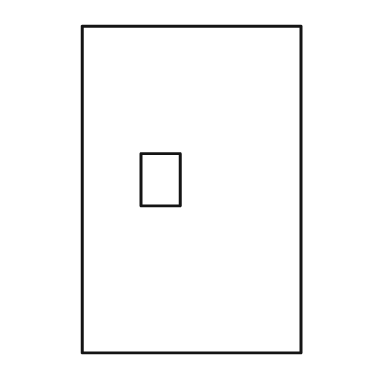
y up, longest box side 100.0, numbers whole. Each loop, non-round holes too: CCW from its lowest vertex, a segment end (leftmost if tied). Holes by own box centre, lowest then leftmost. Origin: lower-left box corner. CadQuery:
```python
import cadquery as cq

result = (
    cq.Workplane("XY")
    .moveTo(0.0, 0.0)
    .lineTo(67.0, 0.0)
    .lineTo(67.0, 100.0)
    .lineTo(0.0, 100.0)
    .close()
    .moveTo(18.0, 45.0)
    .lineTo(30.0, 45.0)
    .lineTo(30.0, 61.0)
    .lineTo(18.0, 61.0)
    .close()
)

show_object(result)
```